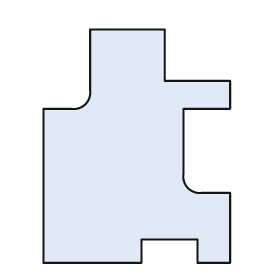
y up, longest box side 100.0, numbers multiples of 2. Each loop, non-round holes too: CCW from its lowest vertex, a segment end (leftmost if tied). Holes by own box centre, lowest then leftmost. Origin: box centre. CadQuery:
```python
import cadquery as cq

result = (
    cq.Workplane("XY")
    .moveTo(-40.0, -50.0)
    .lineTo(2.0, -50.0)
    .lineTo(2.0, -40.0)
    .lineTo(26.0, -40.0)
    .lineTo(26.0, -50.0)
    .lineTo(40.0, -50.0)
    .lineTo(40.0, -20.0)
    .lineTo(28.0, -20.0)
    .threePointArc((22.0, -18.0), (20.0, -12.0))
    .lineTo(20.0, 16.0)
    .lineTo(40.0, 16.0)
    .lineTo(40.0, 28.0)
    .lineTo(12.0, 28.0)
    .lineTo(12.0, 50.0)
    .lineTo(-20.0, 50.0)
    .lineTo(-20.0, 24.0)
    .threePointArc((-22.0, 18.0), (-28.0, 16.0))
    .lineTo(-40.0, 16.0)
    .close()
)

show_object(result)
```